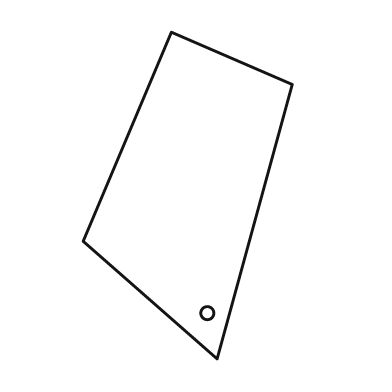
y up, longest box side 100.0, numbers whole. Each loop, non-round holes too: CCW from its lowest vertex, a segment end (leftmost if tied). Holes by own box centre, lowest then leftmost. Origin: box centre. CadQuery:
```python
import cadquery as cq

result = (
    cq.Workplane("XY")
    .moveTo(9.0, -50.0)
    .lineTo(32.0, 34.0)
    .lineTo(-5.0, 50.0)
    .lineTo(-32.0, -14.0)
    .close()
    .moveTo(6.0, -36.0)
    .circle(2.0)
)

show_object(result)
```